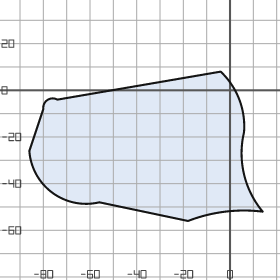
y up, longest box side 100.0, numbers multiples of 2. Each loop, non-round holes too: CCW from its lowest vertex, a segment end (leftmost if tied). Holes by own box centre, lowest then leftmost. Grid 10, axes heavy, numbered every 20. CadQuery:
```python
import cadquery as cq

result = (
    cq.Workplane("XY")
    .moveTo(-18.0, -56.0)
    .threePointArc((-2.0, -52.0), (14.0, -52.0))
    .threePointArc((6.0, -36.0), (6.0, -18.0))
    .threePointArc((4.0, -4.0), (-4.0, 8.0))
    .lineTo(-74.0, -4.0)
    .threePointArc((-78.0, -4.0), (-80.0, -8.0))
    .lineTo(-86.0, -26.0)
    .threePointArc((-76.0, -44.0), (-56.0, -48.0))
    .close()
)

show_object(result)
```